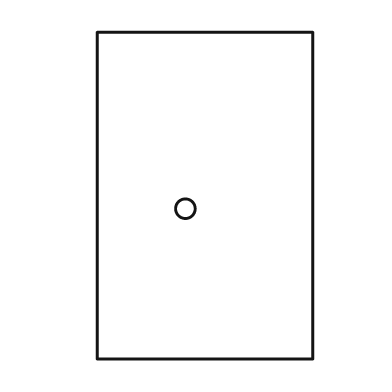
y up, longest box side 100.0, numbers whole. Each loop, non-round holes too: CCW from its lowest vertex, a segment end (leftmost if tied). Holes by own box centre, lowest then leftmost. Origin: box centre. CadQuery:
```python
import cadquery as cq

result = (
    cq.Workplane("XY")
    .moveTo(-33.0, -50.0)
    .lineTo(33.0, -50.0)
    .lineTo(33.0, 50.0)
    .lineTo(-33.0, 50.0)
    .close()
    .moveTo(-6.0, -4.0)
    .circle(3.0)
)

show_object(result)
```